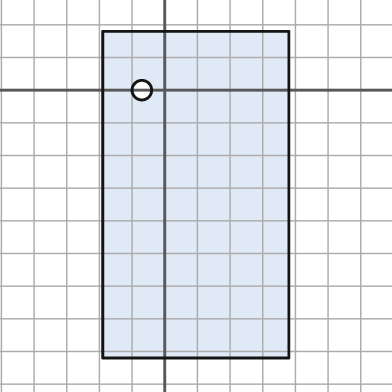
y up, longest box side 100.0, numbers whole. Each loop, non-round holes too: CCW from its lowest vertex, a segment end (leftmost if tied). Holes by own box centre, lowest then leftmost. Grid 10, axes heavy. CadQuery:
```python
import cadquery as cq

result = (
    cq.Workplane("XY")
    .moveTo(-19.0, -82.0)
    .lineTo(38.0, -82.0)
    .lineTo(38.0, 18.0)
    .lineTo(-19.0, 18.0)
    .close()
    .moveTo(-7.0, 0.0)
    .circle(3.0)
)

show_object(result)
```